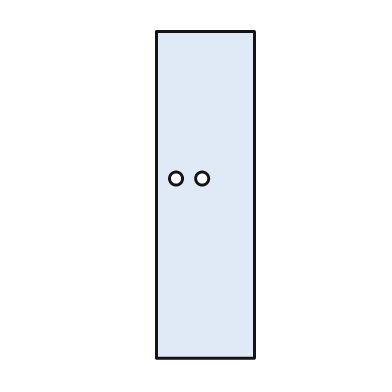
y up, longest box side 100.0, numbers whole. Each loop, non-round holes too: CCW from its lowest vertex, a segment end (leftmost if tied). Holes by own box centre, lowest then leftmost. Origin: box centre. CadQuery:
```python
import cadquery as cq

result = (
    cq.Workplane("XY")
    .moveTo(-15.0, -50.0)
    .lineTo(15.0, -50.0)
    .lineTo(15.0, 50.0)
    .lineTo(-15.0, 50.0)
    .close()
    .moveTo(-9.0, 5.0)
    .circle(2.0)
    .moveTo(-1.0, 5.0)
    .circle(2.0)
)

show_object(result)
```